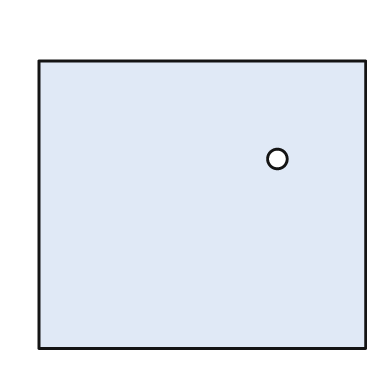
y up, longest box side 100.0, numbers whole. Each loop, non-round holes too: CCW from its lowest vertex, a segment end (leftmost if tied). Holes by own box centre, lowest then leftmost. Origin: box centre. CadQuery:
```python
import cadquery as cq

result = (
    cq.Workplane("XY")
    .moveTo(-50.0, -44.0)
    .lineTo(50.0, -44.0)
    .lineTo(50.0, 44.0)
    .lineTo(-50.0, 44.0)
    .close()
    .moveTo(23.0, 14.0)
    .circle(3.0)
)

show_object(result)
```